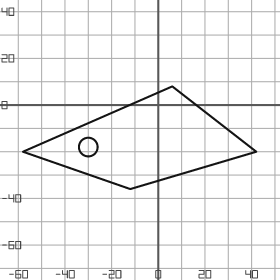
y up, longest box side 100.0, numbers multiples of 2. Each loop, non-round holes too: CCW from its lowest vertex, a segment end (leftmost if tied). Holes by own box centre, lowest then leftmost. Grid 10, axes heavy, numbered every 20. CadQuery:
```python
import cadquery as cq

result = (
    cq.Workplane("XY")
    .moveTo(-12.0, -36.0)
    .lineTo(42.0, -20.0)
    .lineTo(6.0, 8.0)
    .lineTo(-58.0, -20.0)
    .close()
    .moveTo(-30.0, -18.0)
    .circle(4.0)
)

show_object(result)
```